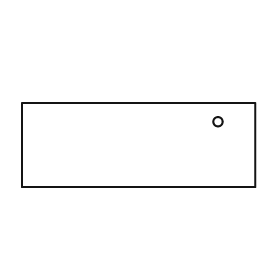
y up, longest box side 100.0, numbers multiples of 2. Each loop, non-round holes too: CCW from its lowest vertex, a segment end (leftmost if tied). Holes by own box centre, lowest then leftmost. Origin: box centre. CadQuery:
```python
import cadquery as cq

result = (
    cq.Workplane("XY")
    .moveTo(-50.0, -18.0)
    .lineTo(50.0, -18.0)
    .lineTo(50.0, 18.0)
    .lineTo(-50.0, 18.0)
    .close()
    .moveTo(34.0, 10.0)
    .circle(2.0)
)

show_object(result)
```